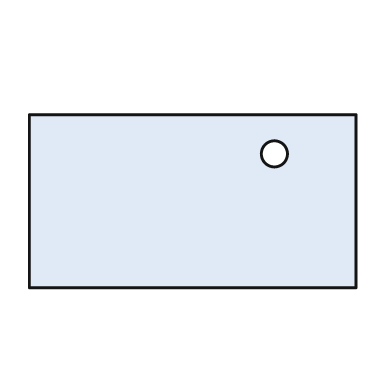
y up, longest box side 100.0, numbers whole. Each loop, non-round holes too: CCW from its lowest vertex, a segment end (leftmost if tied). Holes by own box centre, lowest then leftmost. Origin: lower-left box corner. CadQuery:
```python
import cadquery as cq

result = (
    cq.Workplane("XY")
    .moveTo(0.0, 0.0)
    .lineTo(100.0, 0.0)
    .lineTo(100.0, 53.0)
    .lineTo(0.0, 53.0)
    .close()
    .moveTo(75.0, 41.0)
    .circle(4.0)
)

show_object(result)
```